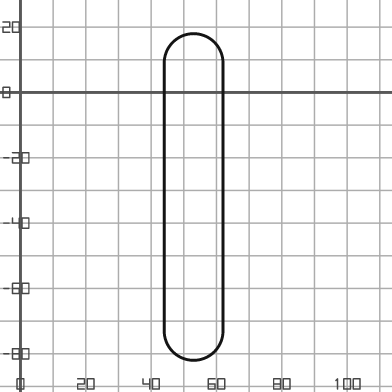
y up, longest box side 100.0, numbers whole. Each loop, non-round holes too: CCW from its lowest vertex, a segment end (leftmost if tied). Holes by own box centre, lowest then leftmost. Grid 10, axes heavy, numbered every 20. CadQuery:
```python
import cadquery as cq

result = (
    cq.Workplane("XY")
    .moveTo(44.0, -73.0)
    .threePointArc((53.0, -82.0), (62.0, -73.0))
    .lineTo(62.0, 9.0)
    .threePointArc((53.0, 18.0), (44.0, 9.0))
    .close()
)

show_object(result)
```